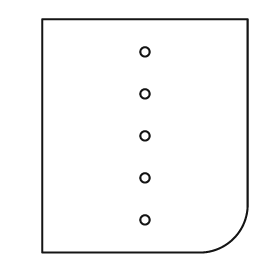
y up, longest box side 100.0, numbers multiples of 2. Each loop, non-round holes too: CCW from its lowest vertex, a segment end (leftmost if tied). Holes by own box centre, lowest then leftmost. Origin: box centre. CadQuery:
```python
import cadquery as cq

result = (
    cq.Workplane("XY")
    .moveTo(-44.0, -50.0)
    .lineTo(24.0, -50.0)
    .threePointArc((38.0, -44.0), (44.0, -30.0))
    .lineTo(44.0, 50.0)
    .lineTo(-44.0, 50.0)
    .close()
    .moveTo(0.0, -36.0)
    .circle(2.0)
    .moveTo(0.0, -18.0)
    .circle(2.0)
    .moveTo(0.0, 0.0)
    .circle(2.0)
    .moveTo(0.0, 18.0)
    .circle(2.0)
    .moveTo(0.0, 36.0)
    .circle(2.0)
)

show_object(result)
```